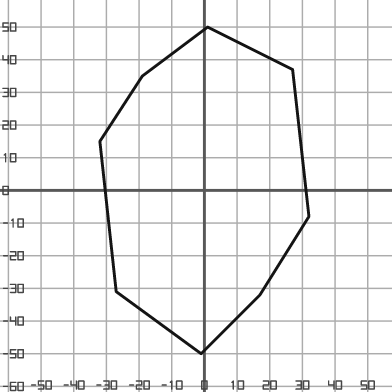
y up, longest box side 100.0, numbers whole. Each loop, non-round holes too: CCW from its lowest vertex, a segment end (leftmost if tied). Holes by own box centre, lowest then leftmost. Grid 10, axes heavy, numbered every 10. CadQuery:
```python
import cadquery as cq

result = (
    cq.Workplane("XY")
    .moveTo(-1.0, -50.0)
    .lineTo(17.0, -32.0)
    .lineTo(32.0, -8.0)
    .lineTo(27.0, 37.0)
    .lineTo(1.0, 50.0)
    .lineTo(-19.0, 35.0)
    .lineTo(-32.0, 15.0)
    .lineTo(-27.0, -31.0)
    .close()
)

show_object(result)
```